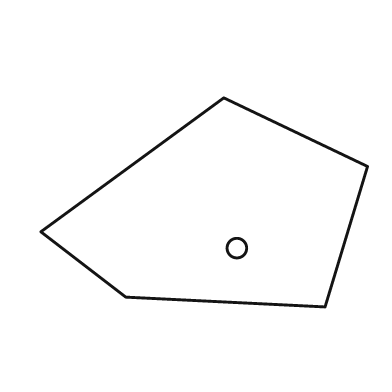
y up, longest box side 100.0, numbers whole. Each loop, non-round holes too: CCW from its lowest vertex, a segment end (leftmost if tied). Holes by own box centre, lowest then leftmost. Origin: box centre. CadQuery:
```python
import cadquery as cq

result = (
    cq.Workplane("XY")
    .moveTo(37.0, -32.0)
    .lineTo(50.0, 11.0)
    .lineTo(6.0, 32.0)
    .lineTo(-50.0, -9.0)
    .lineTo(-24.0, -29.0)
    .close()
    .moveTo(10.0, -14.0)
    .circle(3.0)
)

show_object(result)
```